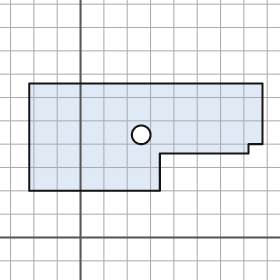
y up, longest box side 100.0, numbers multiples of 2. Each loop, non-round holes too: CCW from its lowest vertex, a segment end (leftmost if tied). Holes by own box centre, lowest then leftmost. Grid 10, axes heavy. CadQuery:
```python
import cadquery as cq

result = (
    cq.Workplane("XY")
    .moveTo(-22.0, 20.0)
    .lineTo(34.0, 20.0)
    .lineTo(34.0, 36.0)
    .lineTo(72.0, 36.0)
    .lineTo(72.0, 40.0)
    .lineTo(78.0, 40.0)
    .lineTo(78.0, 66.0)
    .lineTo(-22.0, 66.0)
    .close()
    .moveTo(26.0, 44.0)
    .circle(4.0)
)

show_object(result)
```